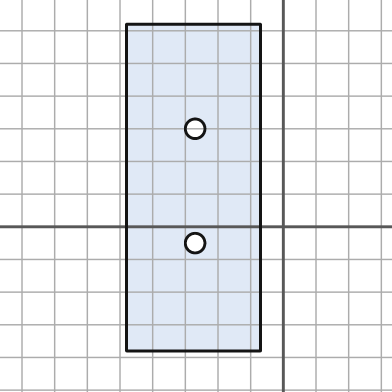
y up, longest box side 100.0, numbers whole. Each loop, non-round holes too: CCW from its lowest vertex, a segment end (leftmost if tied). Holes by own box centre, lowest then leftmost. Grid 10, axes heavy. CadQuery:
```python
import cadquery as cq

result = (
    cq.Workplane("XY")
    .moveTo(-48.0, -38.0)
    .lineTo(-7.0, -38.0)
    .lineTo(-7.0, 62.0)
    .lineTo(-48.0, 62.0)
    .close()
    .moveTo(-27.0, -5.0)
    .circle(3.0)
    .moveTo(-27.0, 30.0)
    .circle(3.0)
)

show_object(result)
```